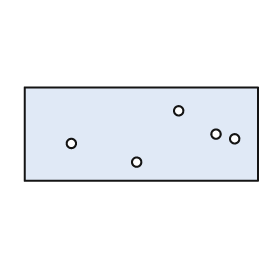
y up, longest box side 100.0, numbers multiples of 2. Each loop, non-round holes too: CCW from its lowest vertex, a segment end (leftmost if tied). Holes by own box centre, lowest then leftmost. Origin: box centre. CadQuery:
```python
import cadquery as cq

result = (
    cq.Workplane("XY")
    .moveTo(-50.0, -20.0)
    .lineTo(50.0, -20.0)
    .lineTo(50.0, 20.0)
    .lineTo(-50.0, 20.0)
    .close()
    .moveTo(-2.0, -12.0)
    .circle(2.0)
    .moveTo(-30.0, -4.0)
    .circle(2.0)
    .moveTo(40.0, -2.0)
    .circle(2.0)
    .moveTo(32.0, 0.0)
    .circle(2.0)
    .moveTo(16.0, 10.0)
    .circle(2.0)
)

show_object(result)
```